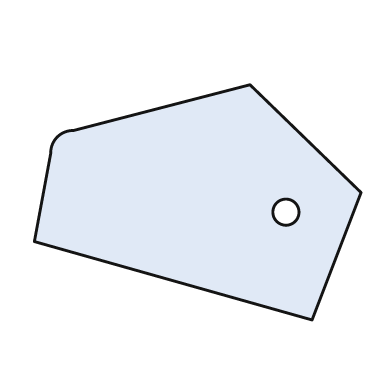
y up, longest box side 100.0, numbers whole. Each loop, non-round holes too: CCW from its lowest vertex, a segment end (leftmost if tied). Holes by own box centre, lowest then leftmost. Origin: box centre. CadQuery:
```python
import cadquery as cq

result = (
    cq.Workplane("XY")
    .moveTo(35.0, -36.0)
    .lineTo(50.0, 3.0)
    .lineTo(16.0, 36.0)
    .lineTo(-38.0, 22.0)
    .threePointArc((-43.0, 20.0), (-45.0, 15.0))
    .lineTo(-50.0, -12.0)
    .close()
    .moveTo(27.0, -3.0)
    .circle(4.0)
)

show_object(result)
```